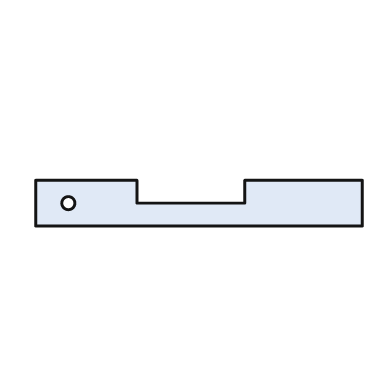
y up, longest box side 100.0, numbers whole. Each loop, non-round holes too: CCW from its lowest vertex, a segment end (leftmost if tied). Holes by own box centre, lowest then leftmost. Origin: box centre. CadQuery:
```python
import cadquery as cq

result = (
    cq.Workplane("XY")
    .moveTo(-50.0, -7.0)
    .lineTo(50.0, -7.0)
    .lineTo(50.0, 7.0)
    .lineTo(14.0, 7.0)
    .lineTo(14.0, 0.0)
    .lineTo(-19.0, 0.0)
    .lineTo(-19.0, 7.0)
    .lineTo(-50.0, 7.0)
    .close()
    .moveTo(-40.0, 0.0)
    .circle(2.0)
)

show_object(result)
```